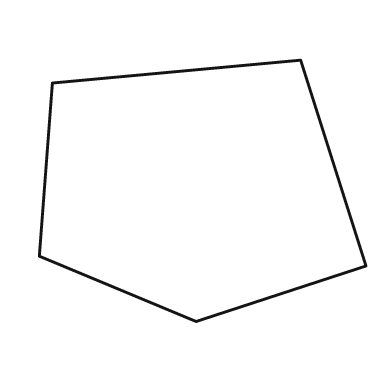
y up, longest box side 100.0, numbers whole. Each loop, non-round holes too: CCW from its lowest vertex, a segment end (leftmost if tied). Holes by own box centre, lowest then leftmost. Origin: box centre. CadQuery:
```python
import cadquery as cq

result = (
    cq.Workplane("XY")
    .moveTo(-2.0, -40.0)
    .lineTo(50.0, -23.0)
    .lineTo(30.0, 40.0)
    .lineTo(-46.0, 33.0)
    .lineTo(-50.0, -20.0)
    .close()
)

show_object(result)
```